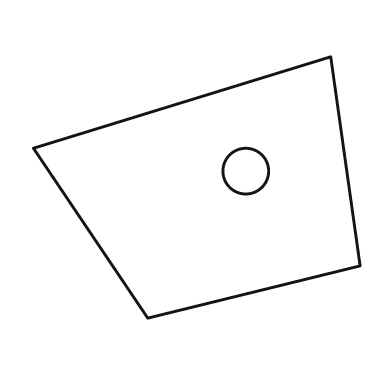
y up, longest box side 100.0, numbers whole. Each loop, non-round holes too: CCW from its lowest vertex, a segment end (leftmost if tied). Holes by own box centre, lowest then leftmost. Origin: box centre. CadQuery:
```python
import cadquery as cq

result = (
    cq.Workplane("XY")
    .moveTo(-15.0, -40.0)
    .lineTo(50.0, -24.0)
    .lineTo(41.0, 40.0)
    .lineTo(-50.0, 12.0)
    .close()
    .moveTo(15.0, 5.0)
    .circle(7.0)
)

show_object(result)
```